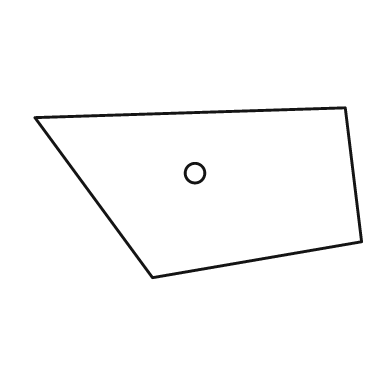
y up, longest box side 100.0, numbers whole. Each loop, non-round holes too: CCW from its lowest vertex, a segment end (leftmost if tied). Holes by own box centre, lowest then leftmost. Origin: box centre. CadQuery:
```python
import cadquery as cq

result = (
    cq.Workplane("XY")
    .moveTo(-14.0, -26.0)
    .lineTo(50.0, -15.0)
    .lineTo(45.0, 26.0)
    .lineTo(-50.0, 23.0)
    .close()
    .moveTo(-1.0, 6.0)
    .circle(3.0)
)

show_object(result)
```